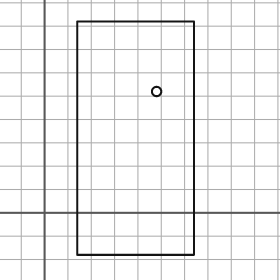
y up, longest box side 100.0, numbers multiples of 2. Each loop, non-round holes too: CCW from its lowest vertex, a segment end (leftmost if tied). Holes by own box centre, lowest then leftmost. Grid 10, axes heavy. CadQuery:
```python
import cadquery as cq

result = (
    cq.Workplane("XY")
    .moveTo(14.0, -18.0)
    .lineTo(64.0, -18.0)
    .lineTo(64.0, 82.0)
    .lineTo(14.0, 82.0)
    .close()
    .moveTo(48.0, 52.0)
    .circle(2.0)
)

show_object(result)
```